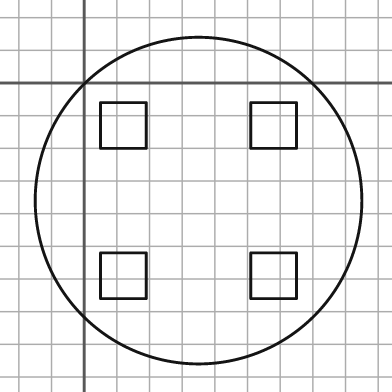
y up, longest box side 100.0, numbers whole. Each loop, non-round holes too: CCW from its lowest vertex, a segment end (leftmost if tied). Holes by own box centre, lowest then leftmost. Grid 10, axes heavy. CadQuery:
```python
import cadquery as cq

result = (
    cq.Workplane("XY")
    .moveTo(35.0, -36.0)
    .circle(50.0)
    .moveTo(5.0, -66.0)
    .lineTo(19.0, -66.0)
    .lineTo(19.0, -52.0)
    .lineTo(5.0, -52.0)
    .close()
    .moveTo(51.0, -66.0)
    .lineTo(65.0, -66.0)
    .lineTo(65.0, -52.0)
    .lineTo(51.0, -52.0)
    .close()
    .moveTo(5.0, -20.0)
    .lineTo(19.0, -20.0)
    .lineTo(19.0, -6.0)
    .lineTo(5.0, -6.0)
    .close()
    .moveTo(51.0, -20.0)
    .lineTo(65.0, -20.0)
    .lineTo(65.0, -6.0)
    .lineTo(51.0, -6.0)
    .close()
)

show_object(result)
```